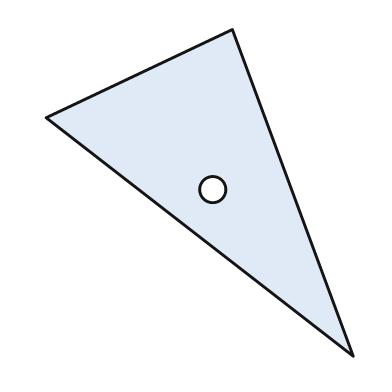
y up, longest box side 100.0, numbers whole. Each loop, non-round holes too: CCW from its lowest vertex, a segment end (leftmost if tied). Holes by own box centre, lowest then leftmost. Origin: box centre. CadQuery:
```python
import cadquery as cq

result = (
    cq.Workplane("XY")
    .moveTo(47.0, -50.0)
    .lineTo(10.0, 50.0)
    .lineTo(-47.0, 23.0)
    .close()
    .moveTo(4.0, 1.0)
    .circle(4.0)
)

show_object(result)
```